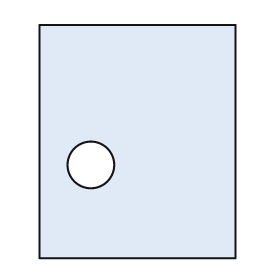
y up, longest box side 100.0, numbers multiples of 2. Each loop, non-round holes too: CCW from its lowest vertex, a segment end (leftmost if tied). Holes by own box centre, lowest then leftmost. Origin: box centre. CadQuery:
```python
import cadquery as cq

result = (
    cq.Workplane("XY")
    .moveTo(-42.0, -50.0)
    .lineTo(42.0, -50.0)
    .lineTo(42.0, 50.0)
    .lineTo(-42.0, 50.0)
    .close()
    .moveTo(-20.0, -10.0)
    .circle(10.0)
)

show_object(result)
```